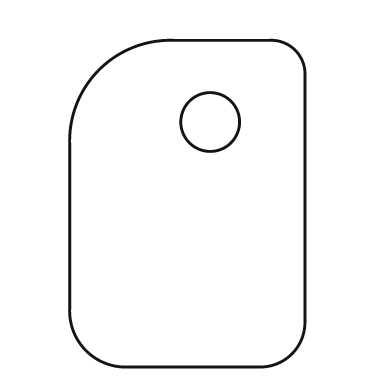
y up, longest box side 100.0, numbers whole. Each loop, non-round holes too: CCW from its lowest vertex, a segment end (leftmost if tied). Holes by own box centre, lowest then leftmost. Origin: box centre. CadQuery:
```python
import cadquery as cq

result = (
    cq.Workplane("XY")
    .moveTo(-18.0, -50.0)
    .lineTo(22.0, -50.0)
    .threePointArc((32.0, -46.0), (36.0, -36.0))
    .lineTo(36.0, 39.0)
    .threePointArc((33.0, 47.0), (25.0, 50.0))
    .lineTo(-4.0, 50.0)
    .threePointArc((-27.0, 41.0), (-36.0, 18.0))
    .lineTo(-36.0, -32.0)
    .threePointArc((-31.0, -45.0), (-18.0, -50.0))
    .close()
    .moveTo(7.0, 25.0)
    .circle(9.0)
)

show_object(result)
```